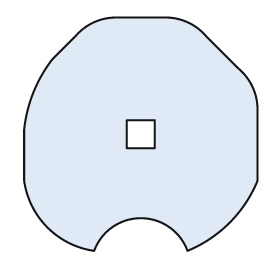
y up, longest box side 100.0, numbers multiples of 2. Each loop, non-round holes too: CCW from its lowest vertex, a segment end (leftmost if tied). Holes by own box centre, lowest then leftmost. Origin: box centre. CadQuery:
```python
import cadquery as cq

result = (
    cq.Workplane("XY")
    .moveTo(-20.0, -50.0)
    .threePointArc((0.0, -36.0), (20.0, -50.0))
    .threePointArc((38.0, -38.0), (50.0, -20.0))
    .lineTo(50.0, 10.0)
    .threePointArc((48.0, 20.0), (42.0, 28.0))
    .lineTo(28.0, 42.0)
    .threePointArc((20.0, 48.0), (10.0, 50.0))
    .lineTo(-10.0, 50.0)
    .threePointArc((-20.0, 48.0), (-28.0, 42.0))
    .lineTo(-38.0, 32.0)
    .threePointArc((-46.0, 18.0), (-50.0, 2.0))
    .lineTo(-50.0, -20.0)
    .threePointArc((-40.0, -40.0), (-20.0, -50.0))
    .close()
    .moveTo(-6.0, -6.0)
    .lineTo(6.0, -6.0)
    .lineTo(6.0, 6.0)
    .lineTo(-6.0, 6.0)
    .close()
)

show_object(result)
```